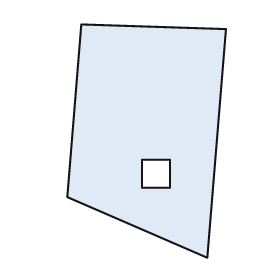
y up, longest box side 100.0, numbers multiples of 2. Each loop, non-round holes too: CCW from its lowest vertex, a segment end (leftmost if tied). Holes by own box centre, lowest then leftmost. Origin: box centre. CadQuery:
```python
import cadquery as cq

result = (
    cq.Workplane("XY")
    .moveTo(26.0, -50.0)
    .lineTo(34.0, 48.0)
    .lineTo(-28.0, 50.0)
    .lineTo(-34.0, -24.0)
    .close()
    .moveTo(-2.0, -20.0)
    .lineTo(10.0, -20.0)
    .lineTo(10.0, -8.0)
    .lineTo(-2.0, -8.0)
    .close()
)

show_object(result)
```